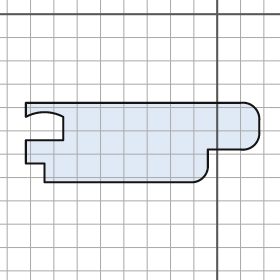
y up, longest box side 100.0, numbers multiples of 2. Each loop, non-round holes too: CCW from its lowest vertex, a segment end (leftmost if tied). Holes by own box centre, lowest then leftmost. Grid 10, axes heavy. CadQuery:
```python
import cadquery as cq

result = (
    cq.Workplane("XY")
    .moveTo(-74.0, -72.0)
    .lineTo(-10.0, -72.0)
    .threePointArc((-6.0, -70.0), (-4.0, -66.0))
    .lineTo(-4.0, -58.0)
    .lineTo(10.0, -58.0)
    .threePointArc((16.0, -56.0), (18.0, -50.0))
    .lineTo(18.0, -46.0)
    .threePointArc((16.0, -40.0), (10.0, -38.0))
    .lineTo(-82.0, -38.0)
    .lineTo(-82.0, -44.0)
    .threePointArc((-74.0, -42.0), (-66.0, -44.0))
    .lineTo(-66.0, -54.0)
    .lineTo(-82.0, -54.0)
    .lineTo(-82.0, -64.0)
    .lineTo(-74.0, -64.0)
    .close()
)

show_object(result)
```